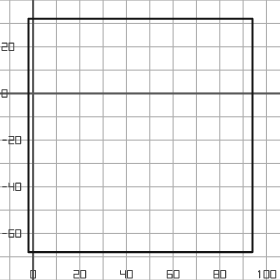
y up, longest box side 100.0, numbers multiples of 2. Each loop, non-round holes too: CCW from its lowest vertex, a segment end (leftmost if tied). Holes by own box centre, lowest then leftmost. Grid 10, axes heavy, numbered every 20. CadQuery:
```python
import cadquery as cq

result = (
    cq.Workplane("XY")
    .moveTo(-2.0, -68.0)
    .lineTo(94.0, -68.0)
    .lineTo(94.0, 32.0)
    .lineTo(-2.0, 32.0)
    .close()
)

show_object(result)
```